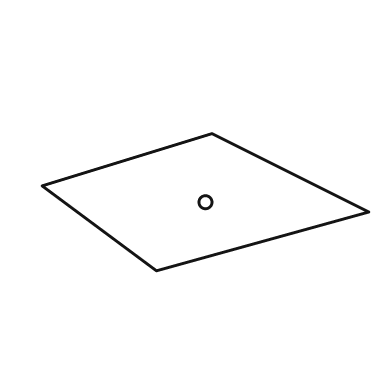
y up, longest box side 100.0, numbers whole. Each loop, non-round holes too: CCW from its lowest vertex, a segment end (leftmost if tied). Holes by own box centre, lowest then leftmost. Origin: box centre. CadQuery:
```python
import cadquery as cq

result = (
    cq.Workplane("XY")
    .moveTo(-15.0, -21.0)
    .lineTo(50.0, -3.0)
    .lineTo(2.0, 21.0)
    .lineTo(-50.0, 5.0)
    .close()
    .moveTo(0.0, 0.0)
    .circle(2.0)
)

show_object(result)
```